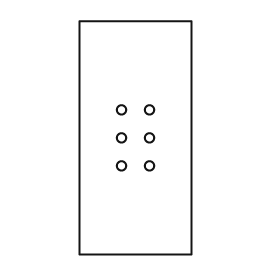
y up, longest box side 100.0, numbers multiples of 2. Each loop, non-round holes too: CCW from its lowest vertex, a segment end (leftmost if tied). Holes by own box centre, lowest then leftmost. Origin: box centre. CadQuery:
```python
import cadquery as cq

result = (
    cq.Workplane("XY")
    .moveTo(-24.0, -50.0)
    .lineTo(24.0, -50.0)
    .lineTo(24.0, 50.0)
    .lineTo(-24.0, 50.0)
    .close()
    .moveTo(-6.0, -12.0)
    .circle(2.0)
    .moveTo(6.0, -12.0)
    .circle(2.0)
    .moveTo(-6.0, 0.0)
    .circle(2.0)
    .moveTo(6.0, 0.0)
    .circle(2.0)
    .moveTo(-6.0, 12.0)
    .circle(2.0)
    .moveTo(6.0, 12.0)
    .circle(2.0)
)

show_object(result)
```